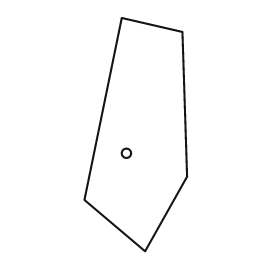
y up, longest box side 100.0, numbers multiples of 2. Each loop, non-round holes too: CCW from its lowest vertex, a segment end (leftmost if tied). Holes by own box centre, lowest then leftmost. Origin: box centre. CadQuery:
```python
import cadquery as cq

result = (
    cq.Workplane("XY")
    .moveTo(4.0, -50.0)
    .lineTo(22.0, -18.0)
    .lineTo(20.0, 44.0)
    .lineTo(-6.0, 50.0)
    .lineTo(-22.0, -28.0)
    .close()
    .moveTo(-4.0, -8.0)
    .circle(2.0)
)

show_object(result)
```